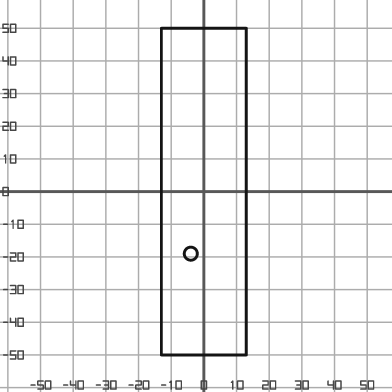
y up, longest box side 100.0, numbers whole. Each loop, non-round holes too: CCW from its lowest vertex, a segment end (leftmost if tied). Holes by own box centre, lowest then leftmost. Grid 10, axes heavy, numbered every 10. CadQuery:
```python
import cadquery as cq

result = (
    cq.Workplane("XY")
    .moveTo(-13.0, -50.0)
    .lineTo(13.0, -50.0)
    .lineTo(13.0, 50.0)
    .lineTo(-13.0, 50.0)
    .close()
    .moveTo(-4.0, -19.0)
    .circle(2.0)
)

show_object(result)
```